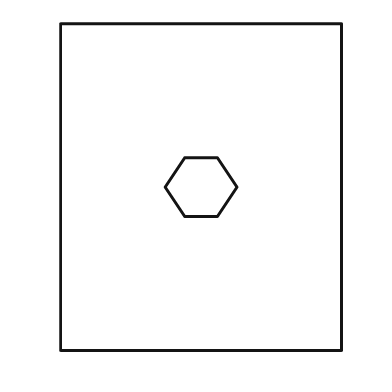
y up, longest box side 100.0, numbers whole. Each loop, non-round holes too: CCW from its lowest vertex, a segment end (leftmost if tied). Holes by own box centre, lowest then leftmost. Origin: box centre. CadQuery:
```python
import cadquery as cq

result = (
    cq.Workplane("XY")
    .moveTo(-43.0, -50.0)
    .lineTo(43.0, -50.0)
    .lineTo(43.0, 50.0)
    .lineTo(-43.0, 50.0)
    .close()
    .moveTo(-5.0, -9.0)
    .lineTo(5.0, -9.0)
    .lineTo(11.0, 0.0)
    .lineTo(5.0, 9.0)
    .lineTo(-5.0, 9.0)
    .lineTo(-11.0, 0.0)
    .close()
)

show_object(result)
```